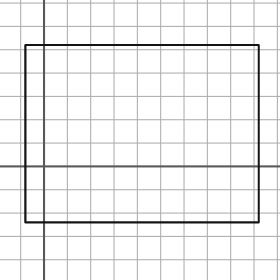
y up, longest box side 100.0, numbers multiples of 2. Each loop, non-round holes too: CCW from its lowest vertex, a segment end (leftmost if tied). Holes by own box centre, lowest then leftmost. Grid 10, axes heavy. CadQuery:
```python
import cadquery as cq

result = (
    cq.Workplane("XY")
    .moveTo(-8.0, -24.0)
    .lineTo(92.0, -24.0)
    .lineTo(92.0, 52.0)
    .lineTo(-8.0, 52.0)
    .close()
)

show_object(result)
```